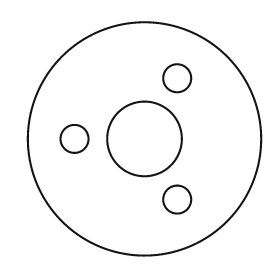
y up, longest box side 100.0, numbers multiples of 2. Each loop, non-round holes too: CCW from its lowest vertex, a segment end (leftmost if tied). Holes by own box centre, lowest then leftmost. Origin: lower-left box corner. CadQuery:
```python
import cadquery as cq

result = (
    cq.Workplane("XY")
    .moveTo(50.0, 50.0)
    .circle(50.0)
    .moveTo(64.0, 24.0)
    .circle(6.0)
    .moveTo(20.0, 50.0)
    .circle(6.0)
    .moveTo(50.0, 50.0)
    .circle(16.0)
    .moveTo(64.0, 76.0)
    .circle(6.0)
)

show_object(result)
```